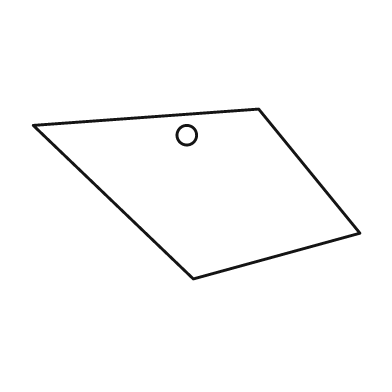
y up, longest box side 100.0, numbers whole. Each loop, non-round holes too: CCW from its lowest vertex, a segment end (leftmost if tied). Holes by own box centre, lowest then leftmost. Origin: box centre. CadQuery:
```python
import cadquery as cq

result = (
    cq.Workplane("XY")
    .moveTo(-1.0, -26.0)
    .lineTo(50.0, -12.0)
    .lineTo(19.0, 26.0)
    .lineTo(-50.0, 21.0)
    .close()
    .moveTo(-3.0, 18.0)
    .circle(3.0)
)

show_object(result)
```